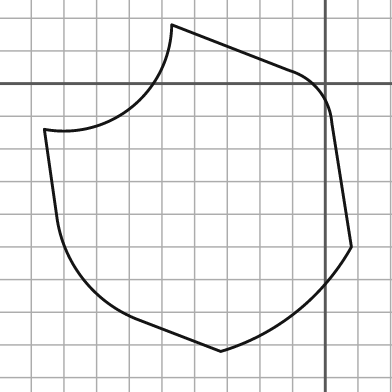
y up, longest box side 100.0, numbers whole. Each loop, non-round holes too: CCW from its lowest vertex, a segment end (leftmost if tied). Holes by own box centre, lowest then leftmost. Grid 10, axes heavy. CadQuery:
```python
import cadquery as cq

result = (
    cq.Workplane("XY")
    .moveTo(-32.0, -82.0)
    .threePointArc((-9.0, -70.0), (8.0, -50.0))
    .lineTo(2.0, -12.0)
    .threePointArc((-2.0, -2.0), (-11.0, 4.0))
    .lineTo(-47.0, 18.0)
    .threePointArc((-59.0, -7.0), (-86.0, -14.0))
    .lineTo(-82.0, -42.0)
    .threePointArc((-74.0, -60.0), (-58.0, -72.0))
    .close()
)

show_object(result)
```